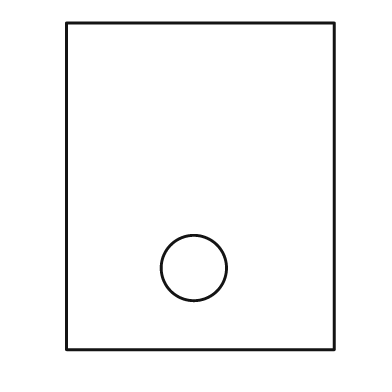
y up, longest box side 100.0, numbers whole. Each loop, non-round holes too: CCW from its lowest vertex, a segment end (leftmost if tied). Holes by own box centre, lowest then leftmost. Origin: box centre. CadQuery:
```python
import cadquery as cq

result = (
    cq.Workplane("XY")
    .moveTo(-41.0, -50.0)
    .lineTo(41.0, -50.0)
    .lineTo(41.0, 50.0)
    .lineTo(-41.0, 50.0)
    .close()
    .moveTo(-2.0, -25.0)
    .circle(10.0)
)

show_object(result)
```